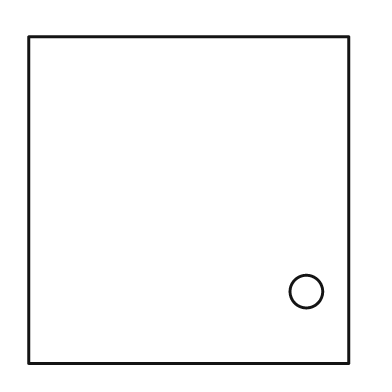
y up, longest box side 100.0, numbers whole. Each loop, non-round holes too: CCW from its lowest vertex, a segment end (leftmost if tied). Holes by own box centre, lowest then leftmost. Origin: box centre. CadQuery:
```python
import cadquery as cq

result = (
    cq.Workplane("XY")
    .moveTo(-49.0, -50.0)
    .lineTo(49.0, -50.0)
    .lineTo(49.0, 50.0)
    .lineTo(-49.0, 50.0)
    .close()
    .moveTo(36.0, -28.0)
    .circle(5.0)
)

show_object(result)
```